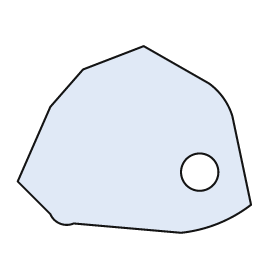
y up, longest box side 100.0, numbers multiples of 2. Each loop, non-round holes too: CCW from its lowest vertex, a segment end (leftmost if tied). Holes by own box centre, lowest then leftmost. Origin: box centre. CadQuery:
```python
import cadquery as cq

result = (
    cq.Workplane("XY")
    .moveTo(20.0, -40.0)
    .threePointArc((36.0, -36.0), (50.0, -28.0))
    .lineTo(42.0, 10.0)
    .threePointArc((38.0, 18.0), (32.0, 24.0))
    .lineTo(4.0, 40.0)
    .lineTo(-22.0, 30.0)
    .lineTo(-36.0, 14.0)
    .lineTo(-50.0, -18.0)
    .lineTo(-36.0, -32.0)
    .threePointArc((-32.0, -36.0), (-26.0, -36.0))
    .close()
    .moveTo(28.0, -14.0)
    .circle(8.0)
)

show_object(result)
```